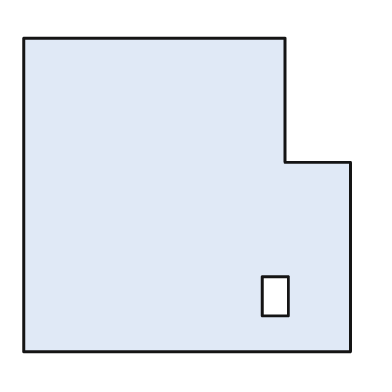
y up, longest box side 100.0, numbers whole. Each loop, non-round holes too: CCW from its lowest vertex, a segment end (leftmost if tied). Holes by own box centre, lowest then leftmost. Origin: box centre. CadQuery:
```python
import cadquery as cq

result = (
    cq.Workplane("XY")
    .moveTo(-50.0, -48.0)
    .lineTo(50.0, -48.0)
    .lineTo(50.0, 10.0)
    .lineTo(30.0, 10.0)
    .lineTo(30.0, 48.0)
    .lineTo(-50.0, 48.0)
    .close()
    .moveTo(23.0, -37.0)
    .lineTo(31.0, -37.0)
    .lineTo(31.0, -25.0)
    .lineTo(23.0, -25.0)
    .close()
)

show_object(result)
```